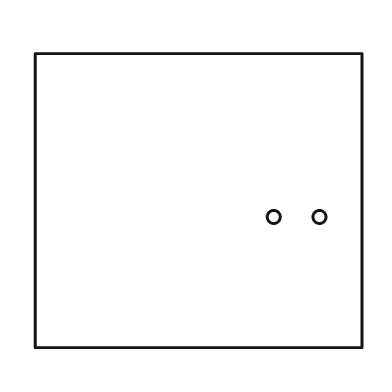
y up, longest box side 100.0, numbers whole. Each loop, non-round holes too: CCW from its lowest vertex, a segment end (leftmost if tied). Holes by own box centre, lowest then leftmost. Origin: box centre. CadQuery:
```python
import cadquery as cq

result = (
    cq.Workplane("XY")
    .moveTo(-50.0, -45.0)
    .lineTo(50.0, -45.0)
    .lineTo(50.0, 45.0)
    .lineTo(-50.0, 45.0)
    .close()
    .moveTo(23.0, -5.0)
    .circle(2.0)
    .moveTo(37.0, -5.0)
    .circle(2.0)
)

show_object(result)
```